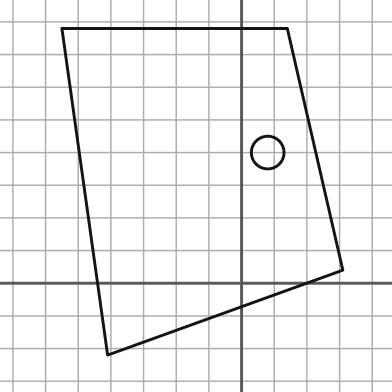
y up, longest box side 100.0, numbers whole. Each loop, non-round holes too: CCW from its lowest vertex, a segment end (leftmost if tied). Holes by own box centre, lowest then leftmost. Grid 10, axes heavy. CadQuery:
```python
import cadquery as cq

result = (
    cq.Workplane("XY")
    .moveTo(-41.0, -22.0)
    .lineTo(31.0, 4.0)
    .lineTo(14.0, 78.0)
    .lineTo(-55.0, 78.0)
    .close()
    .moveTo(8.0, 40.0)
    .circle(5.0)
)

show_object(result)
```